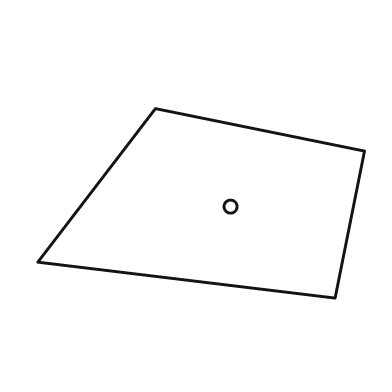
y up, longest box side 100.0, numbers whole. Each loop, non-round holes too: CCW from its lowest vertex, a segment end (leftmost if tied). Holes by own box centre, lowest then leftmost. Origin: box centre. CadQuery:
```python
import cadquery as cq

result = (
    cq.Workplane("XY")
    .moveTo(41.0, -29.0)
    .lineTo(50.0, 16.0)
    .lineTo(-14.0, 29.0)
    .lineTo(-50.0, -18.0)
    .close()
    .moveTo(9.0, -1.0)
    .circle(2.0)
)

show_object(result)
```